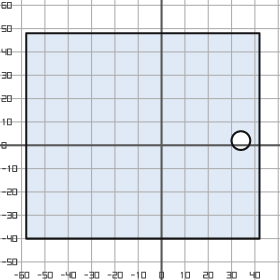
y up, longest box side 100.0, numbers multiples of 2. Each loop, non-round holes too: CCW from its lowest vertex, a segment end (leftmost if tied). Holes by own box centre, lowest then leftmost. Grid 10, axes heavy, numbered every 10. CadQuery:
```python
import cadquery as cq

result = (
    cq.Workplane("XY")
    .moveTo(-58.0, -40.0)
    .lineTo(42.0, -40.0)
    .lineTo(42.0, 48.0)
    .lineTo(-58.0, 48.0)
    .close()
    .moveTo(34.0, 2.0)
    .circle(4.0)
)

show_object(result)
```